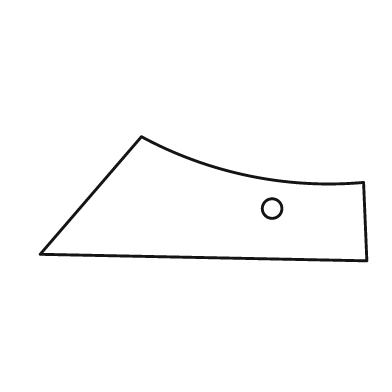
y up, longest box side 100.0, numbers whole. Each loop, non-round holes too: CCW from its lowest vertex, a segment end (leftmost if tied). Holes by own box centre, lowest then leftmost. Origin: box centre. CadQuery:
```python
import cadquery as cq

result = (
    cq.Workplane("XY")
    .moveTo(50.0, -19.0)
    .lineTo(49.0, 5.0)
    .threePointArc((14.0, 7.0), (-19.0, 19.0))
    .lineTo(-50.0, -17.0)
    .close()
    .moveTo(21.0, -3.0)
    .circle(3.0)
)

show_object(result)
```